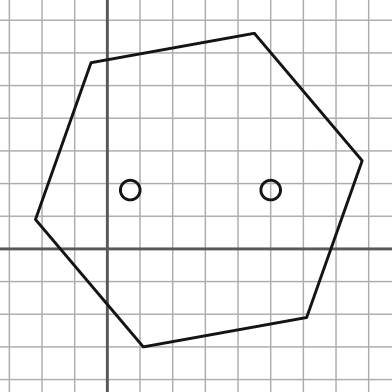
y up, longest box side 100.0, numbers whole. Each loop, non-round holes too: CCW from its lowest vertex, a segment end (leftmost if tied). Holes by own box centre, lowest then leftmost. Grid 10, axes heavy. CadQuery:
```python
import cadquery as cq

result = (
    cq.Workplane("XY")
    .moveTo(11.0, -30.0)
    .lineTo(61.0, -21.0)
    .lineTo(78.0, 27.0)
    .lineTo(45.0, 66.0)
    .lineTo(-5.0, 57.0)
    .lineTo(-22.0, 9.0)
    .close()
    .moveTo(7.0, 18.0)
    .circle(3.0)
    .moveTo(50.0, 18.0)
    .circle(3.0)
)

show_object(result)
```